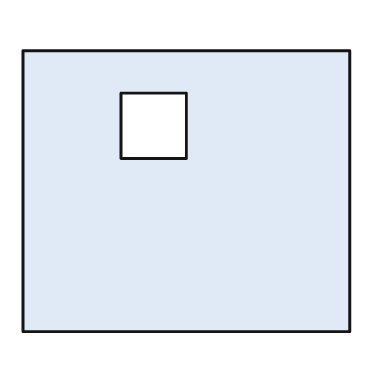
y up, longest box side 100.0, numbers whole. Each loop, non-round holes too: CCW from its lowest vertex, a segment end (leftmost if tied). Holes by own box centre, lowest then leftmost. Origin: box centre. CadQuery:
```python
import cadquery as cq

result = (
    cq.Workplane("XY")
    .moveTo(-50.0, -43.0)
    .lineTo(50.0, -43.0)
    .lineTo(50.0, 43.0)
    .lineTo(-50.0, 43.0)
    .close()
    .moveTo(-20.0, 10.0)
    .lineTo(0.0, 10.0)
    .lineTo(0.0, 30.0)
    .lineTo(-20.0, 30.0)
    .close()
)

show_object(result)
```